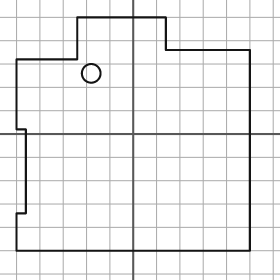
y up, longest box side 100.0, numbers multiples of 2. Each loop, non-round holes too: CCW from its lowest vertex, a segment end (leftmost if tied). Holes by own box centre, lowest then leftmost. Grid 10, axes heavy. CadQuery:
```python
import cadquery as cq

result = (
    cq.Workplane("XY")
    .moveTo(-50.0, -50.0)
    .lineTo(50.0, -50.0)
    .lineTo(50.0, 36.0)
    .lineTo(14.0, 36.0)
    .lineTo(14.0, 50.0)
    .lineTo(-24.0, 50.0)
    .lineTo(-24.0, 32.0)
    .lineTo(-50.0, 32.0)
    .lineTo(-50.0, 2.0)
    .lineTo(-46.0, 2.0)
    .lineTo(-46.0, -34.0)
    .lineTo(-50.0, -34.0)
    .close()
    .moveTo(-18.0, 26.0)
    .circle(4.0)
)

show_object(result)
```